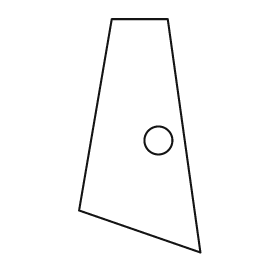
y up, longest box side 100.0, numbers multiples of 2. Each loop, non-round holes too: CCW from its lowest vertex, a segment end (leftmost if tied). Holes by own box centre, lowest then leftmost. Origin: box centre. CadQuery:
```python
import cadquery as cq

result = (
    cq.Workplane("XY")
    .moveTo(26.0, -50.0)
    .lineTo(12.0, 50.0)
    .lineTo(-12.0, 50.0)
    .lineTo(-26.0, -32.0)
    .close()
    .moveTo(8.0, -2.0)
    .circle(6.0)
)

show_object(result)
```